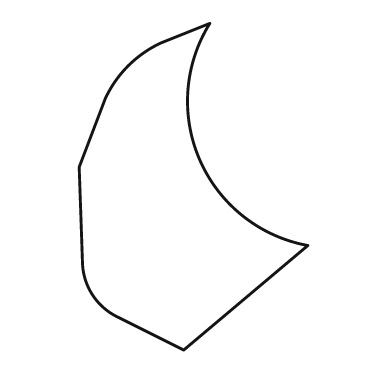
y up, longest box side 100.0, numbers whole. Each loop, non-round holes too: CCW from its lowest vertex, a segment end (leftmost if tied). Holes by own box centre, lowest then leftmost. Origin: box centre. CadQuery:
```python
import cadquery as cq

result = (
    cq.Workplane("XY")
    .moveTo(-3.0, -50.0)
    .lineTo(35.0, -18.0)
    .threePointArc((2.0, 8.0), (5.0, 50.0))
    .lineTo(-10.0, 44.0)
    .threePointArc((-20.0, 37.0), (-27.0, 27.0))
    .lineTo(-35.0, 6.0)
    .lineTo(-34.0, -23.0)
    .threePointArc((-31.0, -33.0), (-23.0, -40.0))
    .close()
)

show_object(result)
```